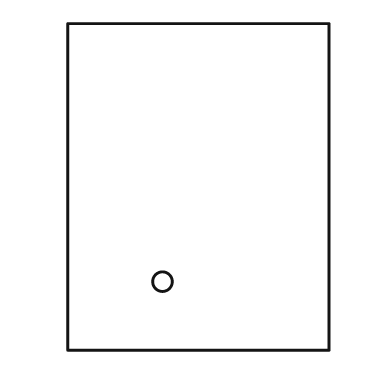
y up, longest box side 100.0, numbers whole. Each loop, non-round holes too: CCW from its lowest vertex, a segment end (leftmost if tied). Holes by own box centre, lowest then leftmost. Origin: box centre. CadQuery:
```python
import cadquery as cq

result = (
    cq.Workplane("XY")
    .moveTo(-40.0, -50.0)
    .lineTo(40.0, -50.0)
    .lineTo(40.0, 50.0)
    .lineTo(-40.0, 50.0)
    .close()
    .moveTo(-11.0, -29.0)
    .circle(3.0)
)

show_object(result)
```